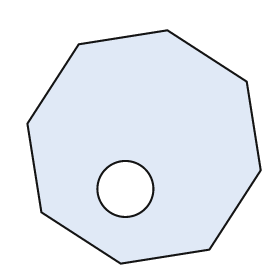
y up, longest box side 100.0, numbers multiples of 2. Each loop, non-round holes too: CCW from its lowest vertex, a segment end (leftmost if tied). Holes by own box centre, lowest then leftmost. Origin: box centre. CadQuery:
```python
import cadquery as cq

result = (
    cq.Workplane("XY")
    .moveTo(-10.0, -50.0)
    .lineTo(28.0, -44.0)
    .lineTo(50.0, -10.0)
    .lineTo(44.0, 28.0)
    .lineTo(10.0, 50.0)
    .lineTo(-28.0, 44.0)
    .lineTo(-50.0, 10.0)
    .lineTo(-44.0, -28.0)
    .close()
    .moveTo(-8.0, -18.0)
    .circle(12.0)
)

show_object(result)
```